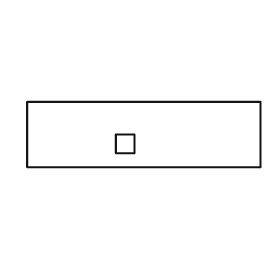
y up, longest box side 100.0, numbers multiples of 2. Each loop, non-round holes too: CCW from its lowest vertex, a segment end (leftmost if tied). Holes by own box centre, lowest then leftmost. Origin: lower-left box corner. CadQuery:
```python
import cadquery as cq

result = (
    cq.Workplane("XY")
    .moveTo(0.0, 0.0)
    .lineTo(100.0, 0.0)
    .lineTo(100.0, 28.0)
    .lineTo(0.0, 28.0)
    .close()
    .moveTo(38.0, 6.0)
    .lineTo(46.0, 6.0)
    .lineTo(46.0, 14.0)
    .lineTo(38.0, 14.0)
    .close()
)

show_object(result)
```